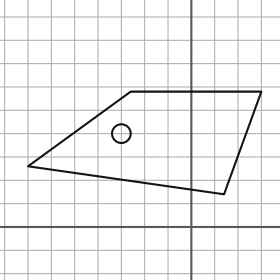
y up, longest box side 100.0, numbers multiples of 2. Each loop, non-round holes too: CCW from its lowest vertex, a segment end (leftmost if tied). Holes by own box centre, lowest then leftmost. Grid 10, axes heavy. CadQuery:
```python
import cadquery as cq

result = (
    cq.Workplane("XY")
    .moveTo(14.0, 14.0)
    .lineTo(30.0, 58.0)
    .lineTo(-26.0, 58.0)
    .lineTo(-70.0, 26.0)
    .close()
    .moveTo(-30.0, 40.0)
    .circle(4.0)
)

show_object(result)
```